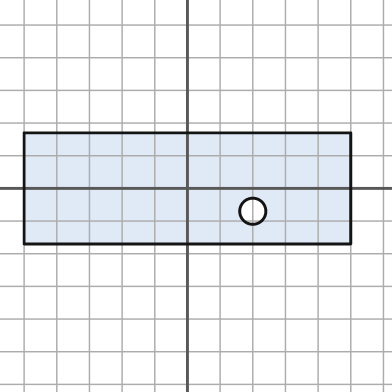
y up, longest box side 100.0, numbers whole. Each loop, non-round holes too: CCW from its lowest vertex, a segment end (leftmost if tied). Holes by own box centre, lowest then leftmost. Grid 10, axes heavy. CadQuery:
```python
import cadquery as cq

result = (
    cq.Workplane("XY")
    .moveTo(-50.0, -17.0)
    .lineTo(50.0, -17.0)
    .lineTo(50.0, 17.0)
    .lineTo(-50.0, 17.0)
    .close()
    .moveTo(20.0, -7.0)
    .circle(4.0)
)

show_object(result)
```